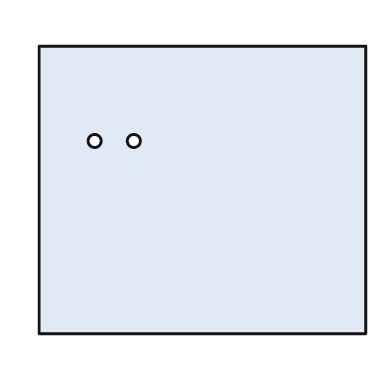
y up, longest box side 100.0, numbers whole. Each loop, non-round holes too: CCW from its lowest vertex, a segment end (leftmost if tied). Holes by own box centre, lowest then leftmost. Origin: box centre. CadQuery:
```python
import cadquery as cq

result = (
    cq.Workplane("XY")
    .moveTo(-50.0, -44.0)
    .lineTo(50.0, -44.0)
    .lineTo(50.0, 44.0)
    .lineTo(-50.0, 44.0)
    .close()
    .moveTo(-33.0, 15.0)
    .circle(2.0)
    .moveTo(-21.0, 15.0)
    .circle(2.0)
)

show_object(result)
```